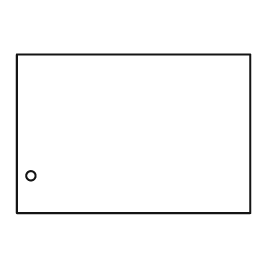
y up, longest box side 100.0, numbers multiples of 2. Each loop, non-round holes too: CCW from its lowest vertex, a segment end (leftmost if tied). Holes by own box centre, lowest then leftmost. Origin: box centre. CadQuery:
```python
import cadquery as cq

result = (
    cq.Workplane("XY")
    .moveTo(-50.0, -34.0)
    .lineTo(50.0, -34.0)
    .lineTo(50.0, 34.0)
    .lineTo(-50.0, 34.0)
    .close()
    .moveTo(-44.0, -18.0)
    .circle(2.0)
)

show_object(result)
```